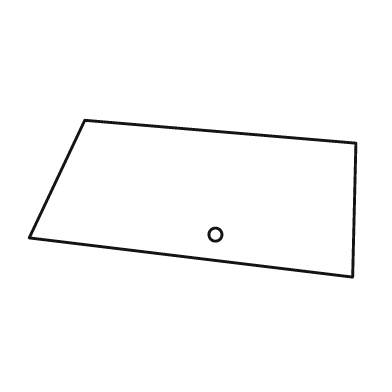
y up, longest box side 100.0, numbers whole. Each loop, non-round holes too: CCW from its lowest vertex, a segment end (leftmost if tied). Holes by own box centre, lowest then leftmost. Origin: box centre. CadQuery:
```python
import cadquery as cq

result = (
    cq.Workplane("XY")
    .moveTo(49.0, -24.0)
    .lineTo(50.0, 17.0)
    .lineTo(-33.0, 24.0)
    .lineTo(-50.0, -12.0)
    .close()
    .moveTo(7.0, -11.0)
    .circle(2.0)
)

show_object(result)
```